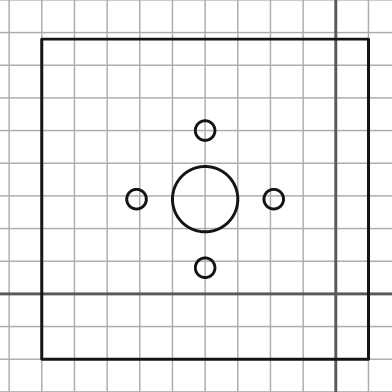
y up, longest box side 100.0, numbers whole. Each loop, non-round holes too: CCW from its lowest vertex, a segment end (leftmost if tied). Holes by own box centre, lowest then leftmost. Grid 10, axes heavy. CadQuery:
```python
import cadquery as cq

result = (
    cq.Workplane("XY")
    .moveTo(-90.0, -20.0)
    .lineTo(10.0, -20.0)
    .lineTo(10.0, 78.0)
    .lineTo(-90.0, 78.0)
    .close()
    .moveTo(-40.0, 8.0)
    .circle(3.0)
    .moveTo(-61.0, 29.0)
    .circle(3.0)
    .moveTo(-40.0, 29.0)
    .circle(10.0)
    .moveTo(-19.0, 29.0)
    .circle(3.0)
    .moveTo(-40.0, 50.0)
    .circle(3.0)
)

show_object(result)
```